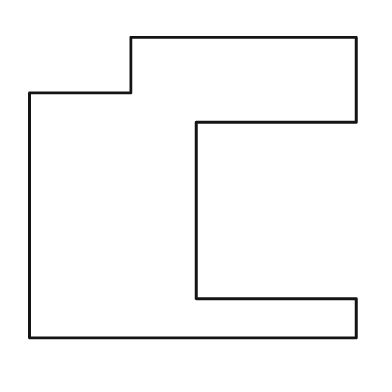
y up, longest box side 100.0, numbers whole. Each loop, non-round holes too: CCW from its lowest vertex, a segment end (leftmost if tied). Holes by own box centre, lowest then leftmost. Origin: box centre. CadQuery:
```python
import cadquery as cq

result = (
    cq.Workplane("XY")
    .moveTo(-50.0, -46.0)
    .lineTo(50.0, -46.0)
    .lineTo(50.0, -34.0)
    .lineTo(1.0, -34.0)
    .lineTo(1.0, 20.0)
    .lineTo(50.0, 20.0)
    .lineTo(50.0, 46.0)
    .lineTo(-19.0, 46.0)
    .lineTo(-19.0, 29.0)
    .lineTo(-50.0, 29.0)
    .close()
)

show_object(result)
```